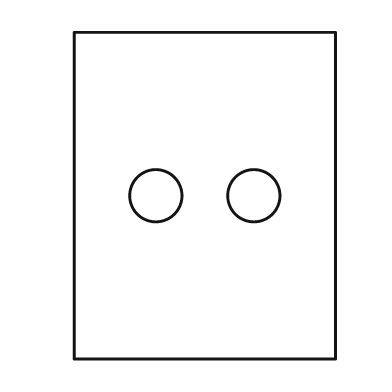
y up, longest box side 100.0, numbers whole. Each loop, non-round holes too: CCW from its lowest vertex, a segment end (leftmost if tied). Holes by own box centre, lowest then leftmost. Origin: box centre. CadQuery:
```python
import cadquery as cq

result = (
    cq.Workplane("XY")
    .moveTo(-40.0, -50.0)
    .lineTo(40.0, -50.0)
    .lineTo(40.0, 50.0)
    .lineTo(-40.0, 50.0)
    .close()
    .moveTo(-15.0, 0.0)
    .circle(8.0)
    .moveTo(15.0, 0.0)
    .circle(8.0)
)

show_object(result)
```